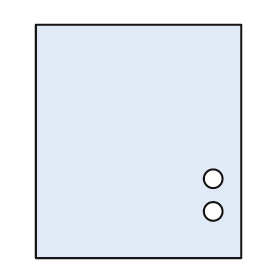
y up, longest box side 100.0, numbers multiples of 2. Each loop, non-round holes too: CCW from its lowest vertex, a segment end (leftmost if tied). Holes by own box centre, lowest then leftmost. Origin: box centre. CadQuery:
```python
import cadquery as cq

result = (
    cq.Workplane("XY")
    .moveTo(-44.0, -50.0)
    .lineTo(44.0, -50.0)
    .lineTo(44.0, 50.0)
    .lineTo(-44.0, 50.0)
    .close()
    .moveTo(32.0, -30.0)
    .circle(4.0)
    .moveTo(32.0, -16.0)
    .circle(4.0)
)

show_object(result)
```